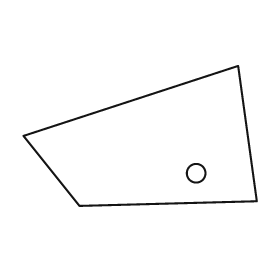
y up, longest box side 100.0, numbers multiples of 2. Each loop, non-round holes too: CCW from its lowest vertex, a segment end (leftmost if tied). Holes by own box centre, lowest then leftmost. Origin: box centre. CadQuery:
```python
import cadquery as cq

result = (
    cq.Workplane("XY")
    .moveTo(-26.0, -30.0)
    .lineTo(50.0, -28.0)
    .lineTo(42.0, 30.0)
    .lineTo(-50.0, 0.0)
    .close()
    .moveTo(24.0, -16.0)
    .circle(4.0)
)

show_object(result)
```